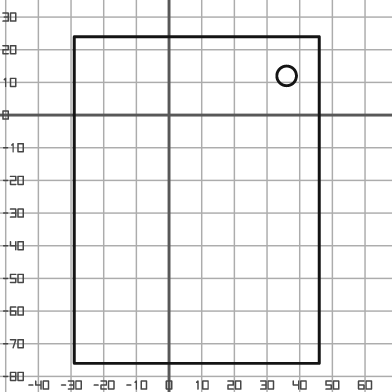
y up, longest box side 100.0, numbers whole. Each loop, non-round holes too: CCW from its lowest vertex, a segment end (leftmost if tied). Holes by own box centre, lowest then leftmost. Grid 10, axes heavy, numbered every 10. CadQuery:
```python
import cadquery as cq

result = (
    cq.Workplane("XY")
    .moveTo(-29.0, -76.0)
    .lineTo(46.0, -76.0)
    .lineTo(46.0, 24.0)
    .lineTo(-29.0, 24.0)
    .close()
    .moveTo(36.0, 12.0)
    .circle(3.0)
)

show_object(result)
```